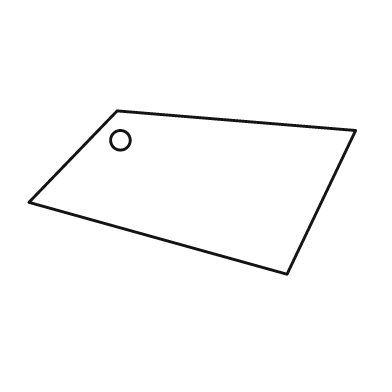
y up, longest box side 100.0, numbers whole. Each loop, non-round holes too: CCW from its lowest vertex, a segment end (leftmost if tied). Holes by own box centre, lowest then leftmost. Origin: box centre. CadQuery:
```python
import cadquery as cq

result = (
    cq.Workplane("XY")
    .moveTo(29.0, -25.0)
    .lineTo(50.0, 19.0)
    .lineTo(-23.0, 25.0)
    .lineTo(-50.0, -3.0)
    .close()
    .moveTo(-22.0, 16.0)
    .circle(3.0)
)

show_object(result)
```